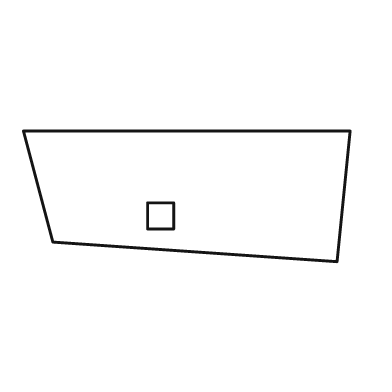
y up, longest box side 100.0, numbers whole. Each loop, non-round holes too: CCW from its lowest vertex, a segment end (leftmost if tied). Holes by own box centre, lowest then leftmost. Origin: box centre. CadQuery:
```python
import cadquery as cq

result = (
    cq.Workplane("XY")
    .moveTo(46.0, -20.0)
    .lineTo(50.0, 20.0)
    .lineTo(-50.0, 20.0)
    .lineTo(-41.0, -14.0)
    .close()
    .moveTo(-12.0, -10.0)
    .lineTo(-4.0, -10.0)
    .lineTo(-4.0, -2.0)
    .lineTo(-12.0, -2.0)
    .close()
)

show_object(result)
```